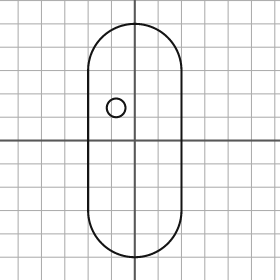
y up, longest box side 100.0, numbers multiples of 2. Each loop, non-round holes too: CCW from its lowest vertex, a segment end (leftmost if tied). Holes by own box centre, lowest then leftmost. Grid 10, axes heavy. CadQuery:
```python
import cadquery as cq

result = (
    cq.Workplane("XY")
    .moveTo(-20.0, -30.0)
    .threePointArc((0.0, -50.0), (20.0, -30.0))
    .lineTo(20.0, 30.0)
    .threePointArc((0.0, 50.0), (-20.0, 30.0))
    .close()
    .moveTo(-8.0, 14.0)
    .circle(4.0)
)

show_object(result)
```